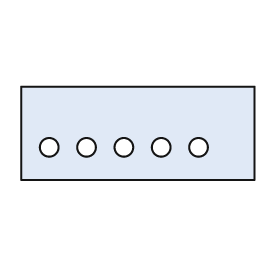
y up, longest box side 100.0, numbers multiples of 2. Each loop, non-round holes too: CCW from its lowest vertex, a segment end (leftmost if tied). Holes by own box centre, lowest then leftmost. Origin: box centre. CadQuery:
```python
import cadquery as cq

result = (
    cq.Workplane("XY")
    .moveTo(-50.0, -20.0)
    .lineTo(50.0, -20.0)
    .lineTo(50.0, 20.0)
    .lineTo(-50.0, 20.0)
    .close()
    .moveTo(-38.0, -6.0)
    .circle(4.0)
    .moveTo(-22.0, -6.0)
    .circle(4.0)
    .moveTo(-6.0, -6.0)
    .circle(4.0)
    .moveTo(10.0, -6.0)
    .circle(4.0)
    .moveTo(26.0, -6.0)
    .circle(4.0)
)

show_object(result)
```